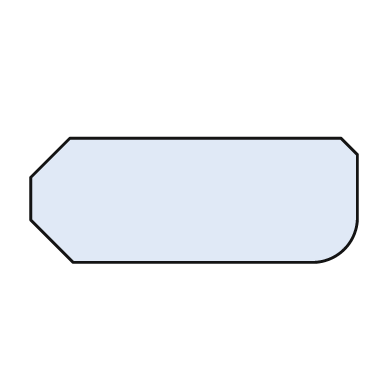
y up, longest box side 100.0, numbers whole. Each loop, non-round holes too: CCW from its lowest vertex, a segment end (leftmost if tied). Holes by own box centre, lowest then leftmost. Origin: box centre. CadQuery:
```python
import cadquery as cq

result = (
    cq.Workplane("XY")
    .moveTo(-37.0, -19.0)
    .lineTo(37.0, -19.0)
    .threePointArc((46.0, -15.0), (50.0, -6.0))
    .lineTo(50.0, 14.0)
    .lineTo(45.0, 19.0)
    .lineTo(-38.0, 19.0)
    .lineTo(-50.0, 7.0)
    .lineTo(-50.0, -6.0)
    .close()
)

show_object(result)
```